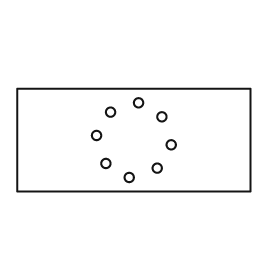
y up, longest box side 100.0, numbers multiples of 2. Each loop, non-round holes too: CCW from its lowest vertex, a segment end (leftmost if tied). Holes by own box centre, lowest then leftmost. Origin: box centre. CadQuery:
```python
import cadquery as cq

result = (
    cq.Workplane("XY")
    .moveTo(-50.0, -22.0)
    .lineTo(50.0, -22.0)
    .lineTo(50.0, 22.0)
    .lineTo(-50.0, 22.0)
    .close()
    .moveTo(-2.0, -16.0)
    .circle(2.0)
    .moveTo(10.0, -12.0)
    .circle(2.0)
    .moveTo(-12.0, -10.0)
    .circle(2.0)
    .moveTo(16.0, -2.0)
    .circle(2.0)
    .moveTo(-16.0, 2.0)
    .circle(2.0)
    .moveTo(12.0, 10.0)
    .circle(2.0)
    .moveTo(-10.0, 12.0)
    .circle(2.0)
    .moveTo(2.0, 16.0)
    .circle(2.0)
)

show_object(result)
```